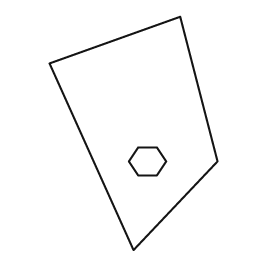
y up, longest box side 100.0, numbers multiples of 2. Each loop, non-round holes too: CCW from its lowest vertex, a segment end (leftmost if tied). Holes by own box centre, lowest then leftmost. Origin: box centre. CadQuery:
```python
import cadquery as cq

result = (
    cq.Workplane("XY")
    .moveTo(0.0, -50.0)
    .lineTo(36.0, -12.0)
    .lineTo(20.0, 50.0)
    .lineTo(-36.0, 30.0)
    .close()
    .moveTo(2.0, -18.0)
    .lineTo(10.0, -18.0)
    .lineTo(14.0, -12.0)
    .lineTo(10.0, -6.0)
    .lineTo(2.0, -6.0)
    .lineTo(-2.0, -12.0)
    .close()
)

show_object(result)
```